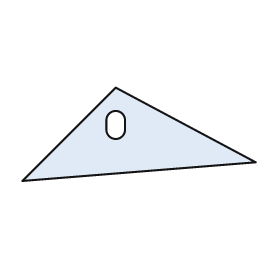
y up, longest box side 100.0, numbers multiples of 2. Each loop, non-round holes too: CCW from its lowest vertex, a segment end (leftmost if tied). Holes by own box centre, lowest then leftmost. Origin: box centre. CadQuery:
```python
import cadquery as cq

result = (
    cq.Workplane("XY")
    .moveTo(-50.0, -20.0)
    .lineTo(50.0, -12.0)
    .lineTo(-10.0, 20.0)
    .close()
    .moveTo(-14.0, 2.0)
    .threePointArc((-10.0, -2.0), (-6.0, 2.0))
    .lineTo(-6.0, 6.0)
    .threePointArc((-10.0, 10.0), (-14.0, 6.0))
    .close()
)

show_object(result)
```